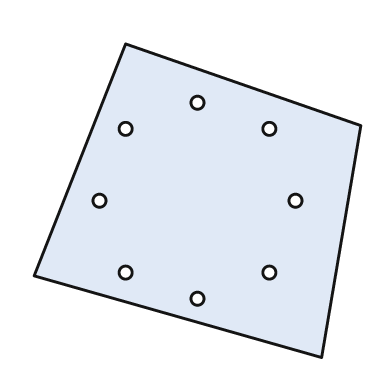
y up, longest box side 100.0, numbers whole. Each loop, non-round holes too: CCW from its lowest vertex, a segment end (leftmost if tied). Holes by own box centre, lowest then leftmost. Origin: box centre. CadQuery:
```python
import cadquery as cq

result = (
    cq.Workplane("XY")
    .moveTo(38.0, -48.0)
    .lineTo(50.0, 23.0)
    .lineTo(-22.0, 48.0)
    .lineTo(-50.0, -23.0)
    .close()
    .moveTo(0.0, -30.0)
    .circle(2.0)
    .moveTo(-22.0, -22.0)
    .circle(2.0)
    .moveTo(22.0, -22.0)
    .circle(2.0)
    .moveTo(-30.0, 0.0)
    .circle(2.0)
    .moveTo(30.0, 0.0)
    .circle(2.0)
    .moveTo(-22.0, 22.0)
    .circle(2.0)
    .moveTo(22.0, 22.0)
    .circle(2.0)
    .moveTo(0.0, 30.0)
    .circle(2.0)
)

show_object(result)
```